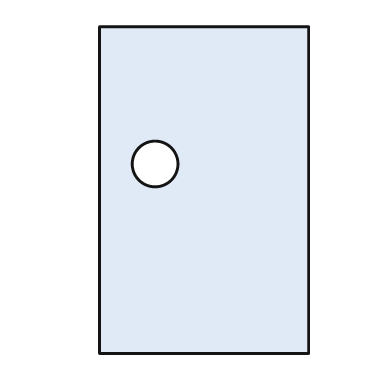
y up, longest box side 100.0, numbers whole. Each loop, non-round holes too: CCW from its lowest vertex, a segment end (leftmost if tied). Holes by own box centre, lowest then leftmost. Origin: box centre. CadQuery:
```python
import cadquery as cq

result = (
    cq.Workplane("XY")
    .moveTo(-32.0, -50.0)
    .lineTo(32.0, -50.0)
    .lineTo(32.0, 50.0)
    .lineTo(-32.0, 50.0)
    .close()
    .moveTo(-15.0, 8.0)
    .circle(7.0)
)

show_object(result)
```